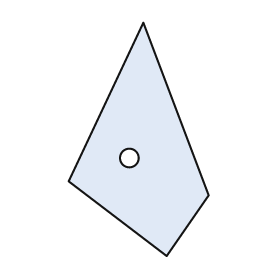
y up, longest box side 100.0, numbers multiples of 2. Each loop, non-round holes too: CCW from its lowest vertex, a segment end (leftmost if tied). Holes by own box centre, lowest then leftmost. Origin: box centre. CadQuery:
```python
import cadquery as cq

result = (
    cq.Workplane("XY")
    .moveTo(12.0, -50.0)
    .lineTo(30.0, -24.0)
    .lineTo(2.0, 50.0)
    .lineTo(-30.0, -18.0)
    .close()
    .moveTo(-4.0, -8.0)
    .circle(4.0)
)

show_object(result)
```